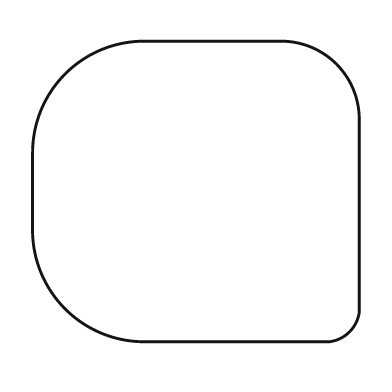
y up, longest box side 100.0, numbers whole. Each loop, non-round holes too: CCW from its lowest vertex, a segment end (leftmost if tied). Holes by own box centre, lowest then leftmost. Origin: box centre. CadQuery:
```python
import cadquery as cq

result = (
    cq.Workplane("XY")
    .moveTo(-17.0, -46.0)
    .lineTo(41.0, -46.0)
    .threePointArc((47.0, -43.0), (50.0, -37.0))
    .lineTo(50.0, 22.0)
    .threePointArc((43.0, 39.0), (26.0, 46.0))
    .lineTo(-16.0, 46.0)
    .threePointArc((-40.0, 36.0), (-50.0, 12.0))
    .lineTo(-50.0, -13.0)
    .threePointArc((-40.0, -36.0), (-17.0, -46.0))
    .close()
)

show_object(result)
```